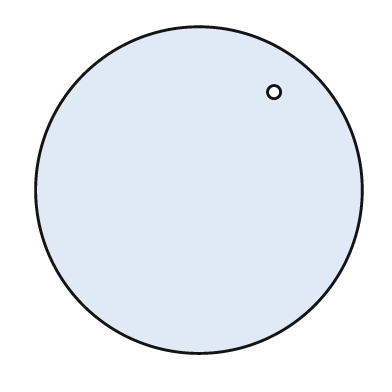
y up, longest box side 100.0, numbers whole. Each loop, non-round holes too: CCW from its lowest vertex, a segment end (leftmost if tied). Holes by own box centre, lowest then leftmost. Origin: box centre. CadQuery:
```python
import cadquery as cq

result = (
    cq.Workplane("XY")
    .moveTo(0.0, 0.0)
    .circle(50.0)
    .moveTo(23.0, 30.0)
    .circle(2.0)
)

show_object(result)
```